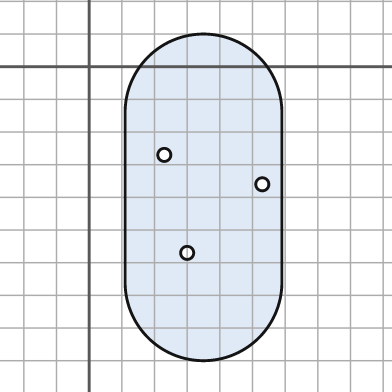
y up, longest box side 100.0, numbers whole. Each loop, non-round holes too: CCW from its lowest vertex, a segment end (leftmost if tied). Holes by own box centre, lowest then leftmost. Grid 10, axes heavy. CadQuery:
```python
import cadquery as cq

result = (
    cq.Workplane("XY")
    .moveTo(11.0, -66.0)
    .threePointArc((35.0, -90.0), (59.0, -66.0))
    .lineTo(59.0, -14.0)
    .threePointArc((35.0, 10.0), (11.0, -14.0))
    .close()
    .moveTo(30.0, -57.0)
    .circle(2.0)
    .moveTo(53.0, -36.0)
    .circle(2.0)
    .moveTo(23.0, -27.0)
    .circle(2.0)
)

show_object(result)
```